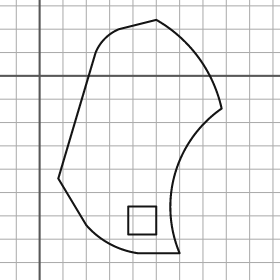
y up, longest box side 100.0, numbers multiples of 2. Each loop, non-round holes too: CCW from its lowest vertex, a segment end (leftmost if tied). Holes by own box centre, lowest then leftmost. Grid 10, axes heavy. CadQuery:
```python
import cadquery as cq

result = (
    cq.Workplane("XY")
    .moveTo(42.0, -76.0)
    .lineTo(60.0, -76.0)
    .threePointArc((58.0, -42.0), (78.0, -14.0))
    .threePointArc((68.0, 8.0), (50.0, 24.0))
    .lineTo(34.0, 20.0)
    .threePointArc((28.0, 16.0), (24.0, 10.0))
    .lineTo(8.0, -44.0)
    .lineTo(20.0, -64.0)
    .threePointArc((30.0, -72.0), (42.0, -76.0))
    .close()
    .moveTo(38.0, -68.0)
    .lineTo(50.0, -68.0)
    .lineTo(50.0, -56.0)
    .lineTo(38.0, -56.0)
    .close()
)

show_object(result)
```